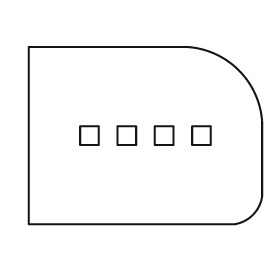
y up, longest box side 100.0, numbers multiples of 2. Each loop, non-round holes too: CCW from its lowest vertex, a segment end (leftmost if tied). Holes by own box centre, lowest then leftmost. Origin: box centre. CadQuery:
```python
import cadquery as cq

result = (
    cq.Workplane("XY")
    .moveTo(-50.0, -38.0)
    .lineTo(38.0, -38.0)
    .threePointArc((46.0, -34.0), (50.0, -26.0))
    .lineTo(50.0, 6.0)
    .threePointArc((40.0, 28.0), (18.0, 38.0))
    .lineTo(-50.0, 38.0)
    .close()
    .moveTo(-28.0, -4.0)
    .lineTo(-20.0, -4.0)
    .lineTo(-20.0, 4.0)
    .lineTo(-28.0, 4.0)
    .close()
    .moveTo(-12.0, -4.0)
    .lineTo(-4.0, -4.0)
    .lineTo(-4.0, 4.0)
    .lineTo(-12.0, 4.0)
    .close()
    .moveTo(4.0, -4.0)
    .lineTo(12.0, -4.0)
    .lineTo(12.0, 4.0)
    .lineTo(4.0, 4.0)
    .close()
    .moveTo(20.0, -4.0)
    .lineTo(28.0, -4.0)
    .lineTo(28.0, 4.0)
    .lineTo(20.0, 4.0)
    .close()
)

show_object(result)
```